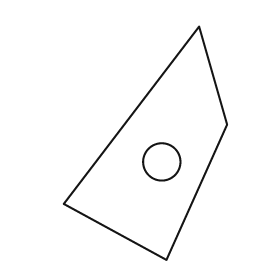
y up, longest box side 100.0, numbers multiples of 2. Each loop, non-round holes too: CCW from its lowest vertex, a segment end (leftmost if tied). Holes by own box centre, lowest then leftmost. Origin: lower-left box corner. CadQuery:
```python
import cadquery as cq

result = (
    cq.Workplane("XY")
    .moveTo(44.0, 0.0)
    .lineTo(70.0, 58.0)
    .lineTo(58.0, 100.0)
    .lineTo(0.0, 24.0)
    .close()
    .moveTo(42.0, 42.0)
    .circle(8.0)
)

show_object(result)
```